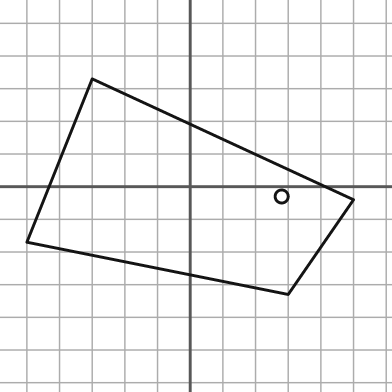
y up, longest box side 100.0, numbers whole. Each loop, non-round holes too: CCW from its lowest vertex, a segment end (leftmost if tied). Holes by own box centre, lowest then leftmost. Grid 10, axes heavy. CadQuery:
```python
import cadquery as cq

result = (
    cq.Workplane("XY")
    .moveTo(30.0, -33.0)
    .lineTo(50.0, -4.0)
    .lineTo(-30.0, 33.0)
    .lineTo(-50.0, -17.0)
    .close()
    .moveTo(28.0, -3.0)
    .circle(2.0)
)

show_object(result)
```